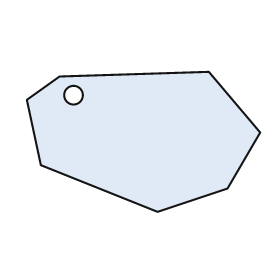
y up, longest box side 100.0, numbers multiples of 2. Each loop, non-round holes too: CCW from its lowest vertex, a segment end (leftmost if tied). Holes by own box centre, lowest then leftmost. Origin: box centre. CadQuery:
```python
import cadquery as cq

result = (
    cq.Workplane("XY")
    .moveTo(6.0, -30.0)
    .lineTo(36.0, -20.0)
    .lineTo(50.0, 4.0)
    .lineTo(28.0, 30.0)
    .lineTo(-36.0, 28.0)
    .lineTo(-50.0, 18.0)
    .lineTo(-44.0, -10.0)
    .close()
    .moveTo(-30.0, 20.0)
    .circle(4.0)
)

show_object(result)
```